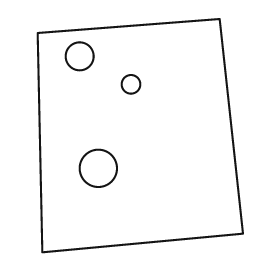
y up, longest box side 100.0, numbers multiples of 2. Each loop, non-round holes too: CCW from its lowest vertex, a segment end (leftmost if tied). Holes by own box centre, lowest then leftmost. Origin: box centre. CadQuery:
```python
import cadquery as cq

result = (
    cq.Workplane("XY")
    .moveTo(-42.0, -50.0)
    .lineTo(44.0, -42.0)
    .lineTo(34.0, 50.0)
    .lineTo(-44.0, 44.0)
    .close()
    .moveTo(-18.0, -14.0)
    .circle(8.0)
    .moveTo(-4.0, 22.0)
    .circle(4.0)
    .moveTo(-26.0, 34.0)
    .circle(6.0)
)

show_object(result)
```